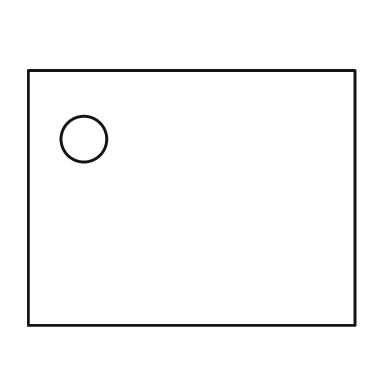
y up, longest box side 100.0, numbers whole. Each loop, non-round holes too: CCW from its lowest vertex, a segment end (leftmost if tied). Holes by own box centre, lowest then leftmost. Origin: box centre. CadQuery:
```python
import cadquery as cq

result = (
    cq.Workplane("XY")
    .moveTo(-50.0, -39.0)
    .lineTo(50.0, -39.0)
    .lineTo(50.0, 39.0)
    .lineTo(-50.0, 39.0)
    .close()
    .moveTo(-33.0, 18.0)
    .circle(7.0)
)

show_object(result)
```